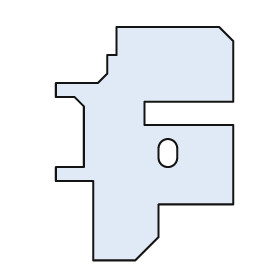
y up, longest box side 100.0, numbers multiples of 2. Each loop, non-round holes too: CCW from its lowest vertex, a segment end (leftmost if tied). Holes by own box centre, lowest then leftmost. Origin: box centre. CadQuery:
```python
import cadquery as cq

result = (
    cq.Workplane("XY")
    .moveTo(-22.0, -50.0)
    .lineTo(-4.0, -50.0)
    .lineTo(6.0, -40.0)
    .lineTo(6.0, -26.0)
    .lineTo(38.0, -26.0)
    .lineTo(38.0, 8.0)
    .lineTo(0.0, 8.0)
    .lineTo(0.0, 18.0)
    .lineTo(38.0, 18.0)
    .lineTo(38.0, 44.0)
    .lineTo(32.0, 50.0)
    .lineTo(-12.0, 50.0)
    .lineTo(-12.0, 38.0)
    .lineTo(-16.0, 38.0)
    .lineTo(-16.0, 30.0)
    .lineTo(-20.0, 26.0)
    .lineTo(-38.0, 26.0)
    .lineTo(-38.0, 20.0)
    .lineTo(-30.0, 20.0)
    .lineTo(-26.0, 16.0)
    .lineTo(-26.0, -10.0)
    .lineTo(-38.0, -10.0)
    .lineTo(-38.0, -16.0)
    .lineTo(-22.0, -16.0)
    .close()
    .moveTo(6.0, -6.0)
    .threePointArc((10.0, -10.0), (14.0, -6.0))
    .lineTo(14.0, -2.0)
    .threePointArc((10.0, 2.0), (6.0, -2.0))
    .close()
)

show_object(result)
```